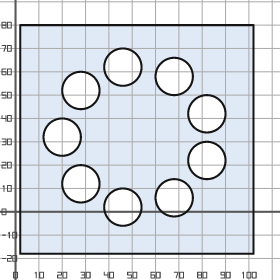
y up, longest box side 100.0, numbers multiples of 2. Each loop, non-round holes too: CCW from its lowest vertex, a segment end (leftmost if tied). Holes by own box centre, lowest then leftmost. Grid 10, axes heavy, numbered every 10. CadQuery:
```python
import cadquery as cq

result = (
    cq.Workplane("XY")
    .moveTo(2.0, -18.0)
    .lineTo(102.0, -18.0)
    .lineTo(102.0, 80.0)
    .lineTo(2.0, 80.0)
    .close()
    .moveTo(46.0, 2.0)
    .circle(8.0)
    .moveTo(68.0, 6.0)
    .circle(8.0)
    .moveTo(28.0, 12.0)
    .circle(8.0)
    .moveTo(82.0, 22.0)
    .circle(8.0)
    .moveTo(20.0, 32.0)
    .circle(8.0)
    .moveTo(82.0, 42.0)
    .circle(8.0)
    .moveTo(28.0, 52.0)
    .circle(8.0)
    .moveTo(68.0, 58.0)
    .circle(8.0)
    .moveTo(46.0, 62.0)
    .circle(8.0)
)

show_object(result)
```